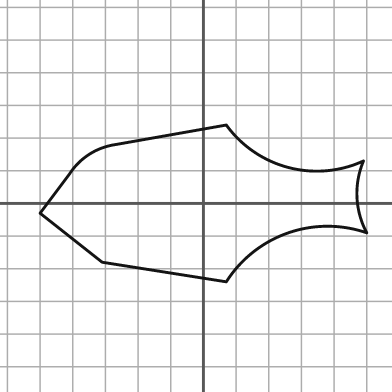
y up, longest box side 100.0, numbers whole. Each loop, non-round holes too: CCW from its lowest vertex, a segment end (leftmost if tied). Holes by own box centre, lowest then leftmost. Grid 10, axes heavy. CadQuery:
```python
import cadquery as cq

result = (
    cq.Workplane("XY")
    .moveTo(7.0, -24.0)
    .threePointArc((26.0, -9.0), (50.0, -9.0))
    .threePointArc((47.0, 2.0), (49.0, 13.0))
    .threePointArc((26.0, 11.0), (7.0, 24.0))
    .lineTo(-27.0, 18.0)
    .threePointArc((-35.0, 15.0), (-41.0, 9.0))
    .lineTo(-50.0, -3.0)
    .lineTo(-31.0, -18.0)
    .close()
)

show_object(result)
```